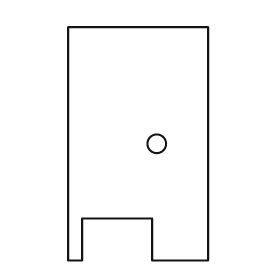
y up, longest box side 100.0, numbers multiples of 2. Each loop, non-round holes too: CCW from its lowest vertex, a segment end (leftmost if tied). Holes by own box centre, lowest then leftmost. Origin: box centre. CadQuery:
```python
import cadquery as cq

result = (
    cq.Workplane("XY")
    .moveTo(-30.0, -50.0)
    .lineTo(-24.0, -50.0)
    .lineTo(-24.0, -32.0)
    .lineTo(6.0, -32.0)
    .lineTo(6.0, -50.0)
    .lineTo(30.0, -50.0)
    .lineTo(30.0, 50.0)
    .lineTo(-30.0, 50.0)
    .close()
    .moveTo(8.0, 0.0)
    .circle(4.0)
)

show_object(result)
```